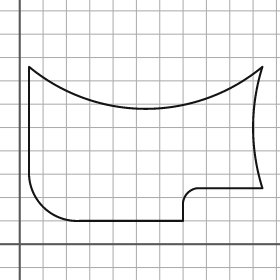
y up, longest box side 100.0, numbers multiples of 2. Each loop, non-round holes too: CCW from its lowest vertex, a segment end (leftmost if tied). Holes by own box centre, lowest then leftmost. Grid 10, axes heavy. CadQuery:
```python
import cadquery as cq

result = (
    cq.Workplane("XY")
    .moveTo(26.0, 10.0)
    .lineTo(70.0, 10.0)
    .lineTo(70.0, 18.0)
    .threePointArc((72.0, 22.0), (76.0, 24.0))
    .lineTo(104.0, 24.0)
    .threePointArc((100.0, 50.0), (104.0, 76.0))
    .threePointArc((54.0, 58.0), (4.0, 76.0))
    .lineTo(4.0, 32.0)
    .threePointArc((10.0, 16.0), (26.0, 10.0))
    .close()
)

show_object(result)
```